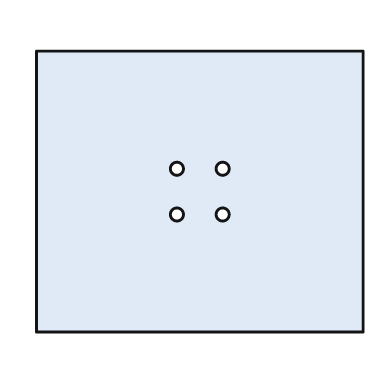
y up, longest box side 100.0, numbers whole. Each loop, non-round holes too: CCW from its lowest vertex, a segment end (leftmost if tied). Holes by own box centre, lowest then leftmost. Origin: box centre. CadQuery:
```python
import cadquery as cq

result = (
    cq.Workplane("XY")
    .moveTo(-50.0, -43.0)
    .lineTo(50.0, -43.0)
    .lineTo(50.0, 43.0)
    .lineTo(-50.0, 43.0)
    .close()
    .moveTo(-7.0, -7.0)
    .circle(2.0)
    .moveTo(7.0, -7.0)
    .circle(2.0)
    .moveTo(-7.0, 7.0)
    .circle(2.0)
    .moveTo(7.0, 7.0)
    .circle(2.0)
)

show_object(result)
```